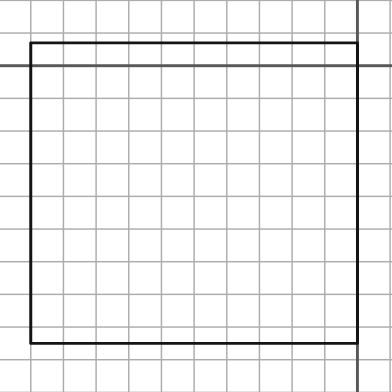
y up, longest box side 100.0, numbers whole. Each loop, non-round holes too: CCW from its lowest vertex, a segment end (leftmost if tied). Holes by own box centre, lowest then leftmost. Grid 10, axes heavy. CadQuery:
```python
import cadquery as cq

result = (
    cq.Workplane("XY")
    .moveTo(-100.0, -85.0)
    .lineTo(0.0, -85.0)
    .lineTo(0.0, 7.0)
    .lineTo(-100.0, 7.0)
    .close()
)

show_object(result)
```